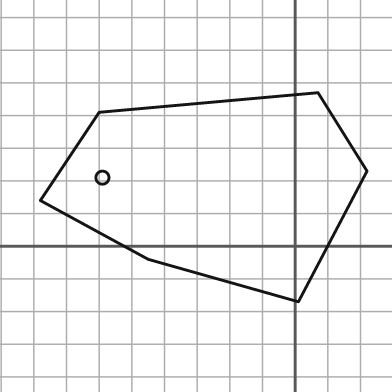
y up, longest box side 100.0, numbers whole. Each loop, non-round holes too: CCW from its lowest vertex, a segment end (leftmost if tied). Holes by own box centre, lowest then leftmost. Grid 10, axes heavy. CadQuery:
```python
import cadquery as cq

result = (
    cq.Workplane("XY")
    .moveTo(1.0, -17.0)
    .lineTo(22.0, 23.0)
    .lineTo(7.0, 47.0)
    .lineTo(-60.0, 41.0)
    .lineTo(-78.0, 14.0)
    .lineTo(-45.0, -4.0)
    .close()
    .moveTo(-59.0, 21.0)
    .circle(2.0)
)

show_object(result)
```